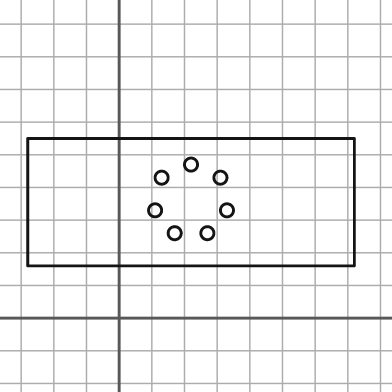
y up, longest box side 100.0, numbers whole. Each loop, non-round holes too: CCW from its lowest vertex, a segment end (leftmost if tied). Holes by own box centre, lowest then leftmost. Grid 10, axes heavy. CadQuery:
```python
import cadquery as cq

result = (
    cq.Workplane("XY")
    .moveTo(-28.0, 16.0)
    .lineTo(72.0, 16.0)
    .lineTo(72.0, 55.0)
    .lineTo(-28.0, 55.0)
    .close()
    .moveTo(17.0, 26.0)
    .circle(2.0)
    .moveTo(27.0, 26.0)
    .circle(2.0)
    .moveTo(11.0, 33.0)
    .circle(2.0)
    .moveTo(33.0, 33.0)
    .circle(2.0)
    .moveTo(13.0, 43.0)
    .circle(2.0)
    .moveTo(31.0, 43.0)
    .circle(2.0)
    .moveTo(22.0, 47.0)
    .circle(2.0)
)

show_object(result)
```